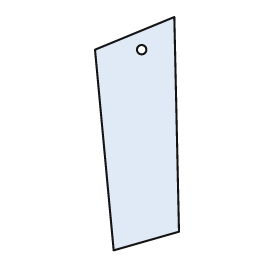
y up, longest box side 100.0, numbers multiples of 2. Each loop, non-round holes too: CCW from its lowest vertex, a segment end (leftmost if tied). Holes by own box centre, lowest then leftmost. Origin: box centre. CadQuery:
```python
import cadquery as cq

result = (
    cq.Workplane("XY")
    .moveTo(-10.0, -50.0)
    .lineTo(18.0, -42.0)
    .lineTo(16.0, 50.0)
    .lineTo(-18.0, 36.0)
    .close()
    .moveTo(2.0, 36.0)
    .circle(2.0)
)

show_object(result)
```